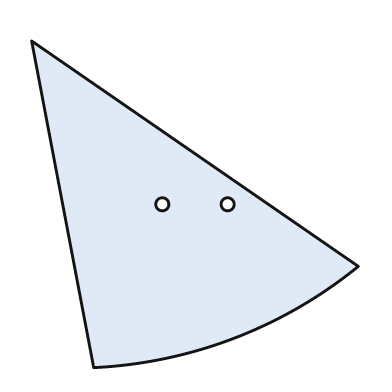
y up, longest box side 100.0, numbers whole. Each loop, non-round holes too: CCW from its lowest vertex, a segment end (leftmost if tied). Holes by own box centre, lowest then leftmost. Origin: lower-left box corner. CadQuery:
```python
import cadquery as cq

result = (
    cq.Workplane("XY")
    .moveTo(19.0, 0.0)
    .threePointArc((62.0, 9.0), (100.0, 31.0))
    .lineTo(0.0, 100.0)
    .close()
    .moveTo(40.0, 50.0)
    .circle(2.0)
    .moveTo(60.0, 50.0)
    .circle(2.0)
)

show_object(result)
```